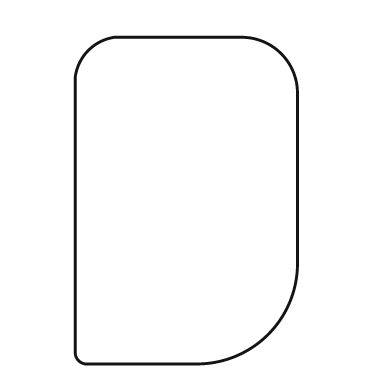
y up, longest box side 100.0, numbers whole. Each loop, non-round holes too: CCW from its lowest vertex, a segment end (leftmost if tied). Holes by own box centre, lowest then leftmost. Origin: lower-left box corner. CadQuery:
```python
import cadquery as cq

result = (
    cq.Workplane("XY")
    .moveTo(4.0, 0.0)
    .lineTo(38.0, 0.0)
    .threePointArc((59.0, 9.0), (68.0, 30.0))
    .lineTo(68.0, 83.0)
    .threePointArc((63.0, 95.0), (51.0, 100.0))
    .lineTo(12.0, 100.0)
    .threePointArc((4.0, 96.0), (0.0, 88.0))
    .lineTo(0.0, 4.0)
    .threePointArc((1.0, 1.0), (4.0, 0.0))
    .close()
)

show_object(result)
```